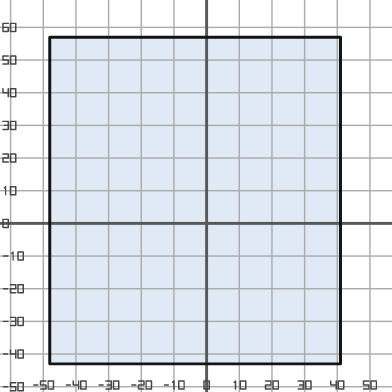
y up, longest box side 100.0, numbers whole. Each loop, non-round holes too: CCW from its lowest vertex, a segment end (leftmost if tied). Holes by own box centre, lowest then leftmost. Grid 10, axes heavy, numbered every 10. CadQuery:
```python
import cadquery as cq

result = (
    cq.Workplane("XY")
    .moveTo(-48.0, -43.0)
    .lineTo(41.0, -43.0)
    .lineTo(41.0, 57.0)
    .lineTo(-48.0, 57.0)
    .close()
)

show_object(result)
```